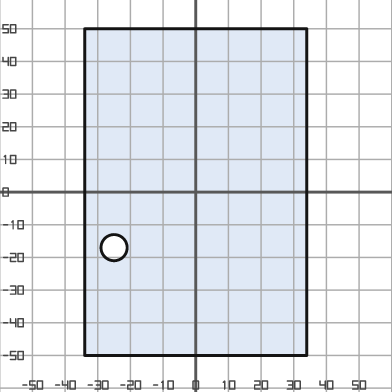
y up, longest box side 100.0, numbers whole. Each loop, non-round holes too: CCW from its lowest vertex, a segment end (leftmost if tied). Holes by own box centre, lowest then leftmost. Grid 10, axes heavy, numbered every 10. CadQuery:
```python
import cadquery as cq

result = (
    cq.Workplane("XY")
    .moveTo(-34.0, -50.0)
    .lineTo(34.0, -50.0)
    .lineTo(34.0, 50.0)
    .lineTo(-34.0, 50.0)
    .close()
    .moveTo(-25.0, -17.0)
    .circle(4.0)
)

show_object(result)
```